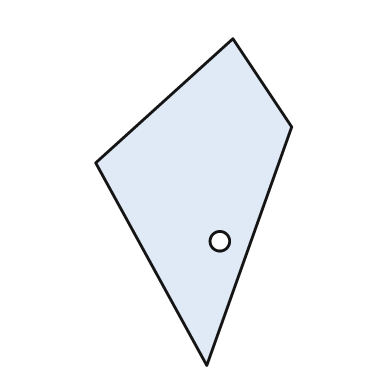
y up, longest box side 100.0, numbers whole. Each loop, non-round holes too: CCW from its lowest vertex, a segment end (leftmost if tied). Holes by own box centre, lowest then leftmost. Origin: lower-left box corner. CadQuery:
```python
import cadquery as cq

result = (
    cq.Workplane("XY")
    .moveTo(34.0, 0.0)
    .lineTo(60.0, 73.0)
    .lineTo(42.0, 100.0)
    .lineTo(0.0, 62.0)
    .close()
    .moveTo(38.0, 38.0)
    .circle(3.0)
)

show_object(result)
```